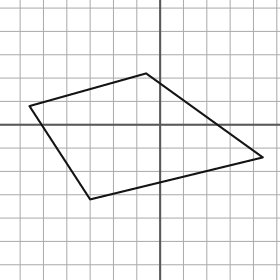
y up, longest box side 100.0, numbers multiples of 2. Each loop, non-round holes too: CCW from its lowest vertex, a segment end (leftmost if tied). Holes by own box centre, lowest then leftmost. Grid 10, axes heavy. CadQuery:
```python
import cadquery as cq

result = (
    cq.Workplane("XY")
    .moveTo(-30.0, -32.0)
    .lineTo(44.0, -14.0)
    .lineTo(-6.0, 22.0)
    .lineTo(-56.0, 8.0)
    .close()
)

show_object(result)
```